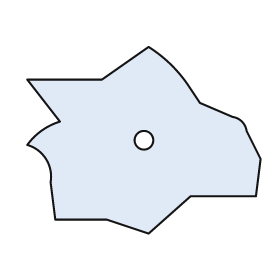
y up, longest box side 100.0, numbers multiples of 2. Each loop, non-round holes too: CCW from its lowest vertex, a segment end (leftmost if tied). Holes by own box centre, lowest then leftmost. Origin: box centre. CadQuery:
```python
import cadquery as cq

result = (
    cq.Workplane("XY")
    .moveTo(2.0, -40.0)
    .lineTo(20.0, -24.0)
    .lineTo(48.0, -24.0)
    .lineTo(50.0, -8.0)
    .lineTo(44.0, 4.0)
    .threePointArc((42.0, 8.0), (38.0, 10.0))
    .lineTo(24.0, 16.0)
    .lineTo(20.0, 22.0)
    .threePointArc((12.0, 32.0), (2.0, 40.0))
    .lineTo(-18.0, 26.0)
    .lineTo(-50.0, 26.0)
    .lineTo(-36.0, 8.0)
    .threePointArc((-44.0, 4.0), (-50.0, -2.0))
    .threePointArc((-42.0, -8.0), (-40.0, -18.0))
    .lineTo(-38.0, -34.0)
    .lineTo(-16.0, -34.0)
    .close()
    .moveTo(0.0, 0.0)
    .circle(4.0)
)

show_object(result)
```